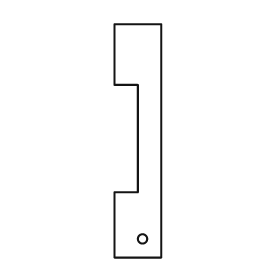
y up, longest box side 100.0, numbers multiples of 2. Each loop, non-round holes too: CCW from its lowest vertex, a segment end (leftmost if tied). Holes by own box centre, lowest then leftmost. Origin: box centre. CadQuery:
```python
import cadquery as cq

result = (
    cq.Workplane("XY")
    .moveTo(-10.0, -50.0)
    .lineTo(10.0, -50.0)
    .lineTo(10.0, 50.0)
    .lineTo(-10.0, 50.0)
    .lineTo(-10.0, 24.0)
    .lineTo(0.0, 24.0)
    .lineTo(0.0, -22.0)
    .lineTo(-10.0, -22.0)
    .close()
    .moveTo(2.0, -42.0)
    .circle(2.0)
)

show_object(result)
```